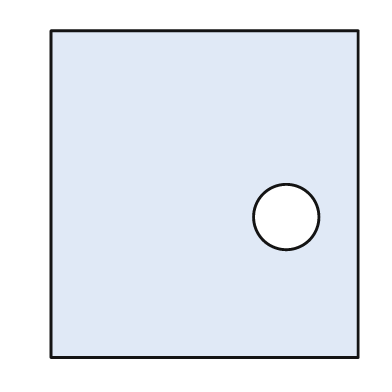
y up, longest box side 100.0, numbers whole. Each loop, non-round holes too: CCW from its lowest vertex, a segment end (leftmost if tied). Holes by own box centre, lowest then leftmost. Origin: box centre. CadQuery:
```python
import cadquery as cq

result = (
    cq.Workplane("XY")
    .moveTo(-47.0, -50.0)
    .lineTo(47.0, -50.0)
    .lineTo(47.0, 50.0)
    .lineTo(-47.0, 50.0)
    .close()
    .moveTo(25.0, -7.0)
    .circle(10.0)
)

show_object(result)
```